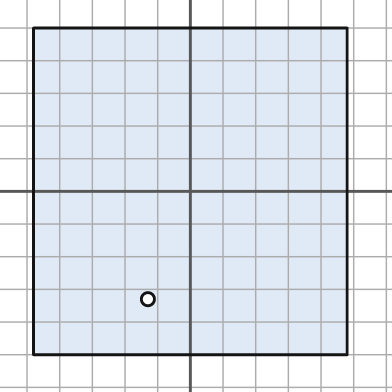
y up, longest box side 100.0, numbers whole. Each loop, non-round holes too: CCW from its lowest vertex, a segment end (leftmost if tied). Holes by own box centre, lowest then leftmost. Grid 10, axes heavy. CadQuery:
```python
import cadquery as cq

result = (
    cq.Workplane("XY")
    .moveTo(-48.0, -50.0)
    .lineTo(48.0, -50.0)
    .lineTo(48.0, 50.0)
    .lineTo(-48.0, 50.0)
    .close()
    .moveTo(-13.0, -33.0)
    .circle(2.0)
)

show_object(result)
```